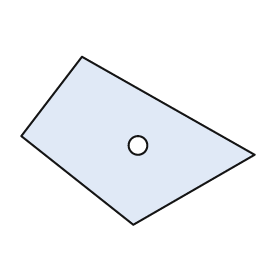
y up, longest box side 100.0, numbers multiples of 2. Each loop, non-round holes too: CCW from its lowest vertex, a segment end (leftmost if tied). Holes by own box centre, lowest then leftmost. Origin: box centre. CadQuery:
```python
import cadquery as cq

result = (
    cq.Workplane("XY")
    .moveTo(-2.0, -36.0)
    .lineTo(50.0, -6.0)
    .lineTo(-24.0, 36.0)
    .lineTo(-50.0, 2.0)
    .close()
    .moveTo(0.0, -2.0)
    .circle(4.0)
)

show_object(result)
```